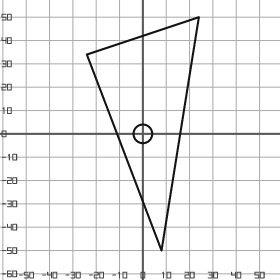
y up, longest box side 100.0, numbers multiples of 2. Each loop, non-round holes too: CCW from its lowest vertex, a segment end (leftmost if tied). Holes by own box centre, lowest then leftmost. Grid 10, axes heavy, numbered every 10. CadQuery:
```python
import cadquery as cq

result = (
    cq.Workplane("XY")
    .moveTo(8.0, -50.0)
    .lineTo(24.0, 50.0)
    .lineTo(-24.0, 34.0)
    .close()
    .moveTo(0.0, 0.0)
    .circle(4.0)
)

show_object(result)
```